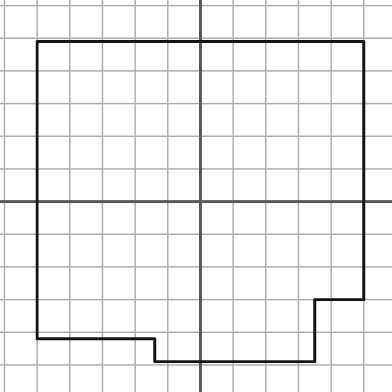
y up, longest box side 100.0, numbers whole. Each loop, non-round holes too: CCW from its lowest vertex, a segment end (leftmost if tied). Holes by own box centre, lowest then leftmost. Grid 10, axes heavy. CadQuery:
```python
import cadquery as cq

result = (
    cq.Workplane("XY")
    .moveTo(-14.0, -49.0)
    .lineTo(35.0, -49.0)
    .lineTo(35.0, -30.0)
    .lineTo(50.0, -30.0)
    .lineTo(50.0, 49.0)
    .lineTo(-50.0, 49.0)
    .lineTo(-50.0, -42.0)
    .lineTo(-14.0, -42.0)
    .close()
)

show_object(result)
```